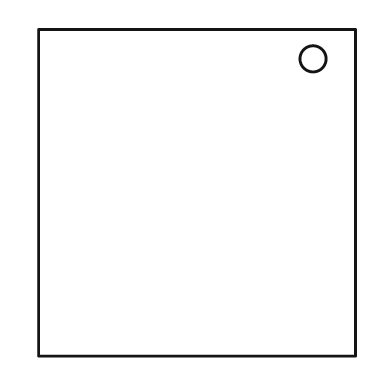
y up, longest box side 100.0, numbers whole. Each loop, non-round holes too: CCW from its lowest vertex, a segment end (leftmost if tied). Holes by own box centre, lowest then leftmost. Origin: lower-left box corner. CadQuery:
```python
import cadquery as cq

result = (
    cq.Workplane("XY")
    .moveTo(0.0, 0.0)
    .lineTo(97.0, 0.0)
    .lineTo(97.0, 100.0)
    .lineTo(0.0, 100.0)
    .close()
    .moveTo(84.0, 91.0)
    .circle(4.0)
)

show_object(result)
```